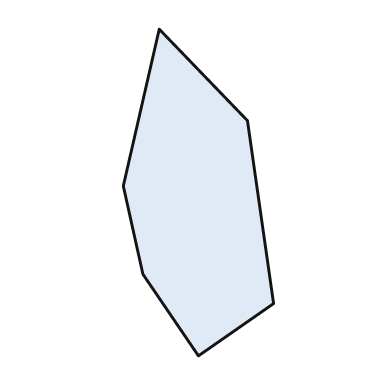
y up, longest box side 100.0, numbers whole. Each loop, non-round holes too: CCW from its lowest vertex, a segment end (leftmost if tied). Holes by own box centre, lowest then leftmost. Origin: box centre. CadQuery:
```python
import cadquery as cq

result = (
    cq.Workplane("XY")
    .moveTo(0.0, -50.0)
    .lineTo(23.0, -34.0)
    .lineTo(15.0, 22.0)
    .lineTo(-12.0, 50.0)
    .lineTo(-23.0, 2.0)
    .lineTo(-17.0, -25.0)
    .close()
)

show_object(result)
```